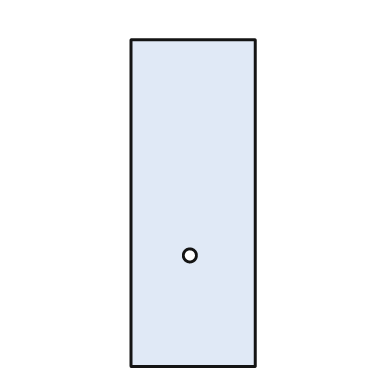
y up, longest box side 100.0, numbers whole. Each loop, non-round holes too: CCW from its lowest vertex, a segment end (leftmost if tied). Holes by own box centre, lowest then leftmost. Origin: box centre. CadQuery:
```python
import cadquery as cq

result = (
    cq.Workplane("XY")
    .moveTo(-19.0, -50.0)
    .lineTo(19.0, -50.0)
    .lineTo(19.0, 50.0)
    .lineTo(-19.0, 50.0)
    .close()
    .moveTo(-1.0, -16.0)
    .circle(2.0)
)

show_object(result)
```